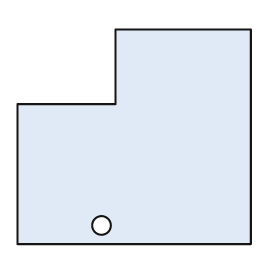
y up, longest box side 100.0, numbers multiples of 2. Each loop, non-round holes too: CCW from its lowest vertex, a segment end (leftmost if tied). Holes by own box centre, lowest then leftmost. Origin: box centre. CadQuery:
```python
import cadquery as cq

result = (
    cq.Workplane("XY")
    .moveTo(-50.0, -46.0)
    .lineTo(50.0, -46.0)
    .lineTo(50.0, 46.0)
    .lineTo(-8.0, 46.0)
    .lineTo(-8.0, 14.0)
    .lineTo(-50.0, 14.0)
    .close()
    .moveTo(-14.0, -38.0)
    .circle(4.0)
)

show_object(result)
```